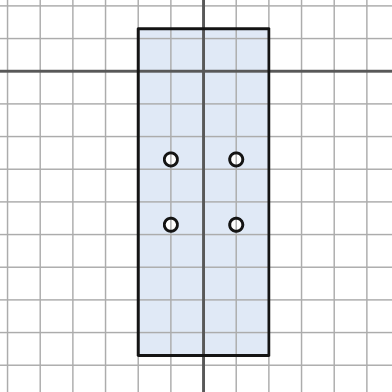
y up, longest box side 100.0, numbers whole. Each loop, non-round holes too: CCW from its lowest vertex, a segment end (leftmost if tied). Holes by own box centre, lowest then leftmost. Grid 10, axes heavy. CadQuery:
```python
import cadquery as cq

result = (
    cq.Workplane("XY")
    .moveTo(-20.0, -87.0)
    .lineTo(20.0, -87.0)
    .lineTo(20.0, 13.0)
    .lineTo(-20.0, 13.0)
    .close()
    .moveTo(-10.0, -47.0)
    .circle(2.0)
    .moveTo(10.0, -47.0)
    .circle(2.0)
    .moveTo(-10.0, -27.0)
    .circle(2.0)
    .moveTo(10.0, -27.0)
    .circle(2.0)
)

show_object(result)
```